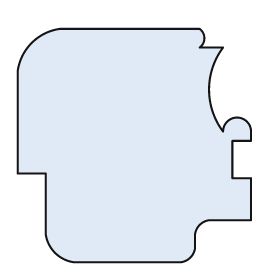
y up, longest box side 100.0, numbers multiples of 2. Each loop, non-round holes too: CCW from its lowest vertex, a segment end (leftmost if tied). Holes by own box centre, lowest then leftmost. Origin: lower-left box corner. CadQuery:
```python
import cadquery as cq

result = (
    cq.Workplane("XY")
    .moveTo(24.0, 0.0)
    .lineTo(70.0, 0.0)
    .threePointArc((74.0, 2.0), (76.0, 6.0))
    .lineTo(76.0, 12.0)
    .threePointArc((78.0, 16.0), (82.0, 18.0))
    .lineTo(100.0, 18.0)
    .lineTo(100.0, 36.0)
    .lineTo(92.0, 36.0)
    .lineTo(92.0, 52.0)
    .lineTo(100.0, 52.0)
    .lineTo(100.0, 56.0)
    .threePointArc((94.0, 62.0), (88.0, 56.0))
    .threePointArc((82.0, 74.0), (88.0, 92.0))
    .lineTo(78.0, 92.0)
    .threePointArc((80.0, 96.0), (78.0, 100.0))
    .lineTo(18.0, 100.0)
    .threePointArc((6.0, 94.0), (0.0, 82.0))
    .lineTo(0.0, 38.0)
    .lineTo(12.0, 38.0)
    .lineTo(12.0, 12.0)
    .threePointArc((16.0, 4.0), (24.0, 0.0))
    .close()
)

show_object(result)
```